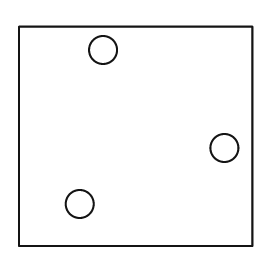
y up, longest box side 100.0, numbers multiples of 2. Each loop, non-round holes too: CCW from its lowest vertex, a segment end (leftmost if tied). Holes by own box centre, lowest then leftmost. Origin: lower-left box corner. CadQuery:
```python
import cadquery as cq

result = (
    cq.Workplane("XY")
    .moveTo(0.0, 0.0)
    .lineTo(100.0, 0.0)
    .lineTo(100.0, 94.0)
    .lineTo(0.0, 94.0)
    .close()
    .moveTo(26.0, 18.0)
    .circle(6.0)
    .moveTo(88.0, 42.0)
    .circle(6.0)
    .moveTo(36.0, 84.0)
    .circle(6.0)
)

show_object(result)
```